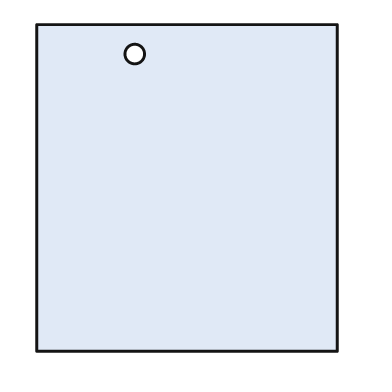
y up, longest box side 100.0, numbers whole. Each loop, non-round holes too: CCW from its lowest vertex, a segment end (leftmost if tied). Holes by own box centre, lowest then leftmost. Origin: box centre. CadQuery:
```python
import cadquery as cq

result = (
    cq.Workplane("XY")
    .moveTo(-46.0, -50.0)
    .lineTo(46.0, -50.0)
    .lineTo(46.0, 50.0)
    .lineTo(-46.0, 50.0)
    .close()
    .moveTo(-16.0, 41.0)
    .circle(3.0)
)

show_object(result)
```